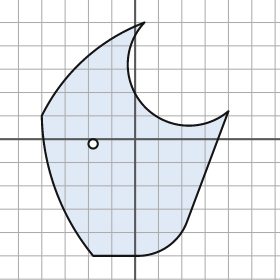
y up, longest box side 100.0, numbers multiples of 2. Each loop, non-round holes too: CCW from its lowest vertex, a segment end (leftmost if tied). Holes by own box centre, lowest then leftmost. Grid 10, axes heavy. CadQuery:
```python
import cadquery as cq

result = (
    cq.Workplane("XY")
    .moveTo(-18.0, -50.0)
    .lineTo(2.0, -50.0)
    .threePointArc((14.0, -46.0), (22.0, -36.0))
    .lineTo(40.0, 12.0)
    .threePointArc((4.0, 14.0), (4.0, 50.0))
    .threePointArc((-22.0, 34.0), (-40.0, 10.0))
    .threePointArc((-34.0, -22.0), (-18.0, -50.0))
    .close()
    .moveTo(-18.0, -2.0)
    .circle(2.0)
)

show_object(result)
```